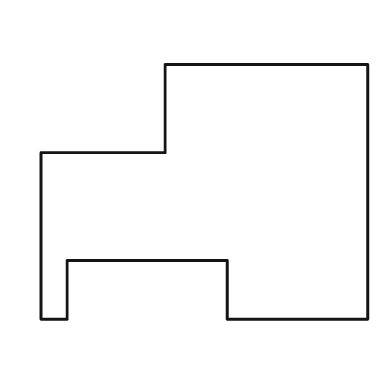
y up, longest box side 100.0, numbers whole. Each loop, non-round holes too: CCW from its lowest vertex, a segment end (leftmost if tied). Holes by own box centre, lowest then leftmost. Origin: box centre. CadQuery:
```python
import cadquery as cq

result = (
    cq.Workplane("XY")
    .moveTo(-50.0, -39.0)
    .lineTo(-42.0, -39.0)
    .lineTo(-42.0, -21.0)
    .lineTo(7.0, -21.0)
    .lineTo(7.0, -39.0)
    .lineTo(50.0, -39.0)
    .lineTo(50.0, 39.0)
    .lineTo(-12.0, 39.0)
    .lineTo(-12.0, 12.0)
    .lineTo(-50.0, 12.0)
    .close()
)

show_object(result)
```